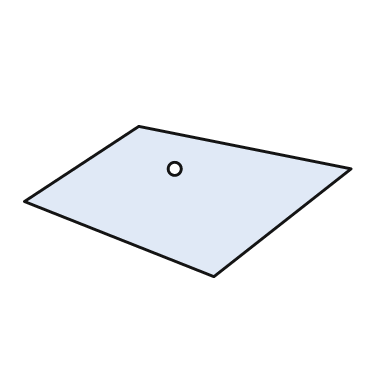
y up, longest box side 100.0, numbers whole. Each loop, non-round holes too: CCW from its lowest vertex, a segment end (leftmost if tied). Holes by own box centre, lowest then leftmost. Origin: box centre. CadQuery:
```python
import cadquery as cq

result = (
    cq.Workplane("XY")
    .moveTo(8.0, -23.0)
    .lineTo(50.0, 10.0)
    .lineTo(-15.0, 23.0)
    .lineTo(-50.0, 0.0)
    .close()
    .moveTo(-4.0, 10.0)
    .circle(2.0)
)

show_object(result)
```